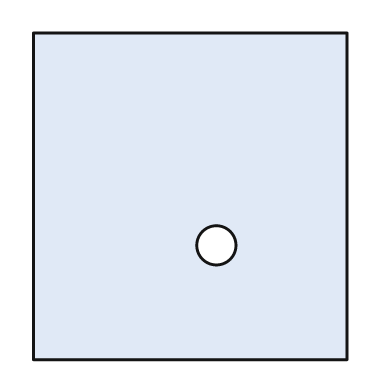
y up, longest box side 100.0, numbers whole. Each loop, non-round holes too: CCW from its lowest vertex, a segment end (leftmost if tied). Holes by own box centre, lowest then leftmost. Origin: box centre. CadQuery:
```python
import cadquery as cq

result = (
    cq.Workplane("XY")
    .moveTo(-48.0, -50.0)
    .lineTo(48.0, -50.0)
    .lineTo(48.0, 50.0)
    .lineTo(-48.0, 50.0)
    .close()
    .moveTo(8.0, -15.0)
    .circle(6.0)
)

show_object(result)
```